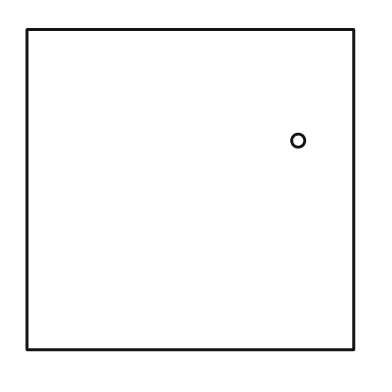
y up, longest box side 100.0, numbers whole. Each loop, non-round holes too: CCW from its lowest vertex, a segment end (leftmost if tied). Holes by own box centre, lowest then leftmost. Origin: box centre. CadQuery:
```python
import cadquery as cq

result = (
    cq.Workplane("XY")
    .moveTo(-50.0, -49.0)
    .lineTo(50.0, -49.0)
    .lineTo(50.0, 49.0)
    .lineTo(-50.0, 49.0)
    .close()
    .moveTo(33.0, 15.0)
    .circle(2.0)
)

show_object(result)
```